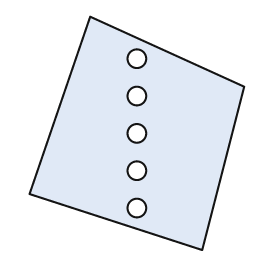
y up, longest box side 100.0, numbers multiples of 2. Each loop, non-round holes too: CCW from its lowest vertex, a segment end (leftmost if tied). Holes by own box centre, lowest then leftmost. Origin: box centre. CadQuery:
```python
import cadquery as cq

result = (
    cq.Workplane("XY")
    .moveTo(28.0, -50.0)
    .lineTo(46.0, 20.0)
    .lineTo(-20.0, 50.0)
    .lineTo(-46.0, -26.0)
    .close()
    .moveTo(0.0, -32.0)
    .circle(4.0)
    .moveTo(0.0, -16.0)
    .circle(4.0)
    .moveTo(0.0, 0.0)
    .circle(4.0)
    .moveTo(0.0, 16.0)
    .circle(4.0)
    .moveTo(0.0, 32.0)
    .circle(4.0)
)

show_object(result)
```